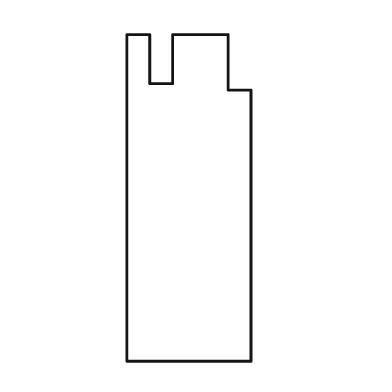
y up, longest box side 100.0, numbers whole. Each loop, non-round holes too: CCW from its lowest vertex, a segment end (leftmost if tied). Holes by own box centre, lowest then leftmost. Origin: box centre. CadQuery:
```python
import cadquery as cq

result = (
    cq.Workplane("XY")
    .moveTo(-19.0, -50.0)
    .lineTo(19.0, -50.0)
    .lineTo(19.0, 33.0)
    .lineTo(12.0, 33.0)
    .lineTo(12.0, 50.0)
    .lineTo(-5.0, 50.0)
    .lineTo(-5.0, 35.0)
    .lineTo(-12.0, 35.0)
    .lineTo(-12.0, 50.0)
    .lineTo(-19.0, 50.0)
    .close()
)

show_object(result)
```